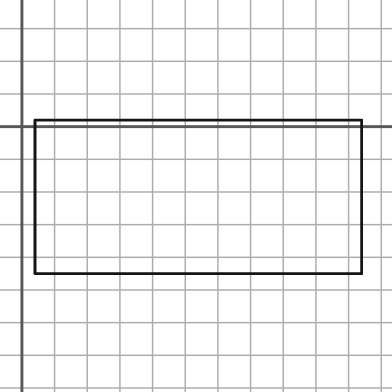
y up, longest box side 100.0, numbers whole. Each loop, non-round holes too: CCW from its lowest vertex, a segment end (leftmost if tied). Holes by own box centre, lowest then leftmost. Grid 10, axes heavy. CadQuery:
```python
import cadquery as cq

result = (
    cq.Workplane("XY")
    .moveTo(4.0, -45.0)
    .lineTo(104.0, -45.0)
    .lineTo(104.0, 2.0)
    .lineTo(4.0, 2.0)
    .close()
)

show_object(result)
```